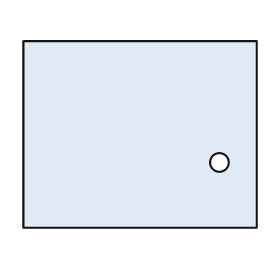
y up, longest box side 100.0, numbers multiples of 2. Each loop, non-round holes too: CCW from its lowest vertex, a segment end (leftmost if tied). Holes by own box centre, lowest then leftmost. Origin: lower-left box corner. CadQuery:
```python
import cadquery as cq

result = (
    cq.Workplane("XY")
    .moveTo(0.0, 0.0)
    .lineTo(100.0, 0.0)
    .lineTo(100.0, 80.0)
    .lineTo(0.0, 80.0)
    .close()
    .moveTo(84.0, 28.0)
    .circle(4.0)
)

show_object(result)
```